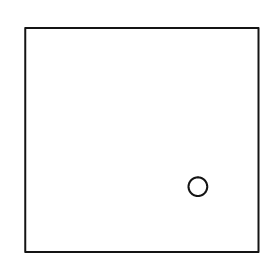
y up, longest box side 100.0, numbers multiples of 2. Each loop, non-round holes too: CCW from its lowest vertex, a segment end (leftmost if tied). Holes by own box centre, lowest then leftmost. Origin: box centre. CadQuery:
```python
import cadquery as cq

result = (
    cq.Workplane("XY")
    .moveTo(-50.0, -48.0)
    .lineTo(50.0, -48.0)
    .lineTo(50.0, 48.0)
    .lineTo(-50.0, 48.0)
    .close()
    .moveTo(24.0, -20.0)
    .circle(4.0)
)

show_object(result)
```